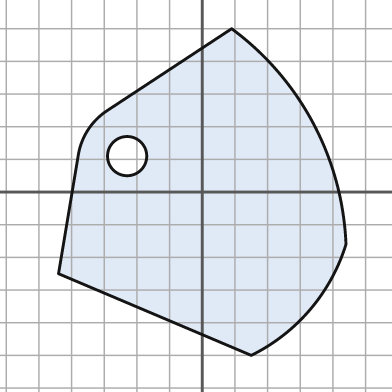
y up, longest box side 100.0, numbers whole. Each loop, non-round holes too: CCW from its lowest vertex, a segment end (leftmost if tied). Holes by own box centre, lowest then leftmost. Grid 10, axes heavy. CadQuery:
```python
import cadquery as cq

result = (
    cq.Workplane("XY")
    .moveTo(15.0, -50.0)
    .threePointArc((33.0, -36.0), (44.0, -16.0))
    .threePointArc((34.0, 21.0), (9.0, 50.0))
    .lineTo(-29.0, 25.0)
    .threePointArc((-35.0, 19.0), (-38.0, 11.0))
    .lineTo(-44.0, -25.0)
    .close()
    .moveTo(-23.0, 11.0)
    .circle(6.0)
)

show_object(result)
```